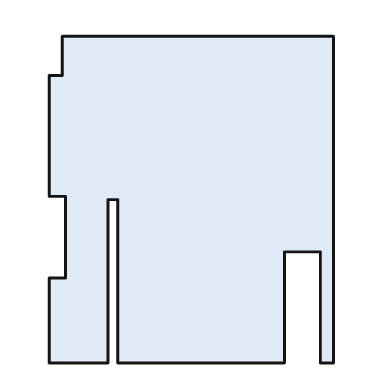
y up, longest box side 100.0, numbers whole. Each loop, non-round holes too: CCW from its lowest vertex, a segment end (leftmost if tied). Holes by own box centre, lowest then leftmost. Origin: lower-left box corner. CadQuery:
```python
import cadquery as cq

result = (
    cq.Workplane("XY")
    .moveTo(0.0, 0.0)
    .lineTo(18.0, 0.0)
    .lineTo(18.0, 50.0)
    .lineTo(21.0, 50.0)
    .lineTo(21.0, 0.0)
    .lineTo(72.0, 0.0)
    .lineTo(72.0, 34.0)
    .lineTo(83.0, 34.0)
    .lineTo(83.0, 0.0)
    .lineTo(87.0, 0.0)
    .lineTo(87.0, 100.0)
    .lineTo(4.0, 100.0)
    .lineTo(4.0, 88.0)
    .lineTo(0.0, 88.0)
    .lineTo(0.0, 51.0)
    .lineTo(5.0, 51.0)
    .lineTo(5.0, 26.0)
    .lineTo(0.0, 26.0)
    .close()
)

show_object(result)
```